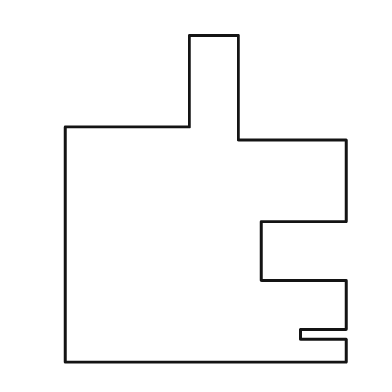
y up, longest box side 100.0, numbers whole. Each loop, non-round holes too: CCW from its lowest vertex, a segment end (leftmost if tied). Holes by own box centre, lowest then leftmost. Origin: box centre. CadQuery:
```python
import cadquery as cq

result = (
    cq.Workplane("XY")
    .moveTo(-43.0, -50.0)
    .lineTo(43.0, -50.0)
    .lineTo(43.0, -43.0)
    .lineTo(29.0, -43.0)
    .lineTo(29.0, -40.0)
    .lineTo(43.0, -40.0)
    .lineTo(43.0, -25.0)
    .lineTo(17.0, -25.0)
    .lineTo(17.0, -7.0)
    .lineTo(43.0, -7.0)
    .lineTo(43.0, 18.0)
    .lineTo(10.0, 18.0)
    .lineTo(10.0, 50.0)
    .lineTo(-5.0, 50.0)
    .lineTo(-5.0, 22.0)
    .lineTo(-43.0, 22.0)
    .close()
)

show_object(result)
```